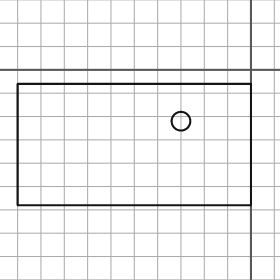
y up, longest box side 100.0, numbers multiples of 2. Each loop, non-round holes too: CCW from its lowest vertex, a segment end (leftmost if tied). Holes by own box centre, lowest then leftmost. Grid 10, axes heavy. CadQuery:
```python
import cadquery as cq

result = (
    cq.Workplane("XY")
    .moveTo(-100.0, -58.0)
    .lineTo(0.0, -58.0)
    .lineTo(0.0, -6.0)
    .lineTo(-100.0, -6.0)
    .close()
    .moveTo(-30.0, -22.0)
    .circle(4.0)
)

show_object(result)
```